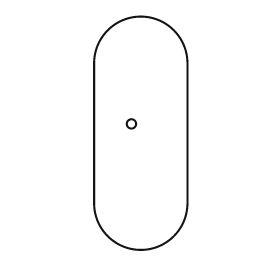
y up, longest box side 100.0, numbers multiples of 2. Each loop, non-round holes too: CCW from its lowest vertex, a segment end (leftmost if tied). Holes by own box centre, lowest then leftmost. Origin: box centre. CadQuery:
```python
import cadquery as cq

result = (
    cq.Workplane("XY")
    .moveTo(-20.0, -30.0)
    .threePointArc((0.0, -50.0), (20.0, -30.0))
    .lineTo(20.0, 30.0)
    .threePointArc((0.0, 50.0), (-20.0, 30.0))
    .close()
    .moveTo(-4.0, 4.0)
    .circle(2.0)
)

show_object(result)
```